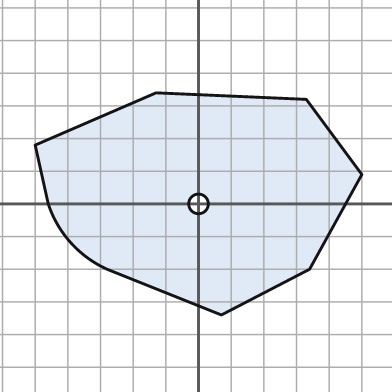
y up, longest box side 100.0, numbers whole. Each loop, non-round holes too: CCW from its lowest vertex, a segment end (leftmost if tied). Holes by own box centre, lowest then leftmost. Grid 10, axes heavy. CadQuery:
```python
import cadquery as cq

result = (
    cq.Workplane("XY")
    .moveTo(7.0, -34.0)
    .lineTo(34.0, -20.0)
    .lineTo(50.0, 9.0)
    .lineTo(33.0, 32.0)
    .lineTo(-13.0, 34.0)
    .lineTo(-50.0, 18.0)
    .lineTo(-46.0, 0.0)
    .threePointArc((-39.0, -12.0), (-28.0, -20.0))
    .close()
    .moveTo(0.0, 0.0)
    .circle(3.0)
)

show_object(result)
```